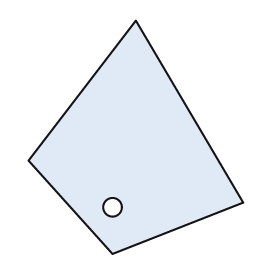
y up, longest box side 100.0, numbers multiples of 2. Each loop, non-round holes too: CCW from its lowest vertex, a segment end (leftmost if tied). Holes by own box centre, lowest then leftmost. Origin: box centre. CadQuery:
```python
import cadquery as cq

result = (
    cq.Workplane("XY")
    .moveTo(-10.0, -50.0)
    .lineTo(46.0, -28.0)
    .lineTo(0.0, 50.0)
    .lineTo(-46.0, -10.0)
    .close()
    .moveTo(-10.0, -30.0)
    .circle(4.0)
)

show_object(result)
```